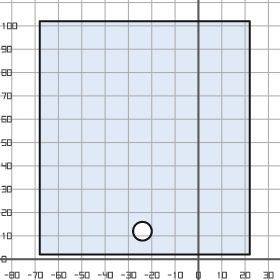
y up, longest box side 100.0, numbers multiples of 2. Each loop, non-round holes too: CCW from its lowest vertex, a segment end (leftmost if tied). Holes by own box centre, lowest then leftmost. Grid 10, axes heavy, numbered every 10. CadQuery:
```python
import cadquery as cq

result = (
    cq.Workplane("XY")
    .moveTo(-68.0, 2.0)
    .lineTo(22.0, 2.0)
    .lineTo(22.0, 102.0)
    .lineTo(-68.0, 102.0)
    .close()
    .moveTo(-24.0, 12.0)
    .circle(4.0)
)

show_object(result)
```